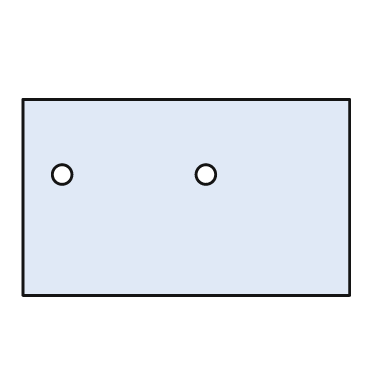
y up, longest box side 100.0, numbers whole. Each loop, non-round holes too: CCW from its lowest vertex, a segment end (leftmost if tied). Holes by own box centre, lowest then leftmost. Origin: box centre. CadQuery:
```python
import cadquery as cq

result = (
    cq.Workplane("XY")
    .moveTo(-50.0, -30.0)
    .lineTo(50.0, -30.0)
    .lineTo(50.0, 30.0)
    .lineTo(-50.0, 30.0)
    .close()
    .moveTo(-38.0, 7.0)
    .circle(3.0)
    .moveTo(6.0, 7.0)
    .circle(3.0)
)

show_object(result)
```